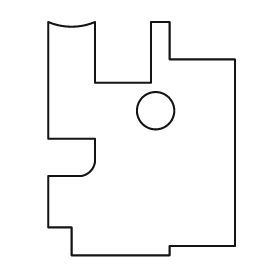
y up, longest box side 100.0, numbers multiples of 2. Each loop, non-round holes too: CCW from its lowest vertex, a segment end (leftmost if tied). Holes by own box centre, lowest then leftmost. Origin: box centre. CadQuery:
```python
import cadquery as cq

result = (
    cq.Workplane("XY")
    .moveTo(-30.0, -50.0)
    .lineTo(12.0, -50.0)
    .lineTo(12.0, -46.0)
    .lineTo(40.0, -46.0)
    .lineTo(40.0, 34.0)
    .lineTo(12.0, 34.0)
    .lineTo(12.0, 50.0)
    .lineTo(4.0, 50.0)
    .lineTo(4.0, 24.0)
    .lineTo(-20.0, 24.0)
    .lineTo(-20.0, 50.0)
    .threePointArc((-30.0, 48.0), (-40.0, 50.0))
    .lineTo(-40.0, 0.0)
    .lineTo(-20.0, 0.0)
    .lineTo(-20.0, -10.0)
    .threePointArc((-22.0, -14.0), (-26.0, -16.0))
    .lineTo(-40.0, -16.0)
    .lineTo(-40.0, -38.0)
    .lineTo(-30.0, -38.0)
    .close()
    .moveTo(6.0, 12.0)
    .circle(8.0)
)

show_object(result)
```